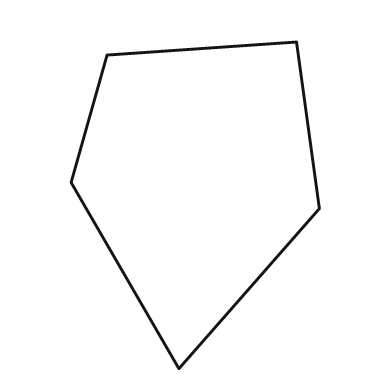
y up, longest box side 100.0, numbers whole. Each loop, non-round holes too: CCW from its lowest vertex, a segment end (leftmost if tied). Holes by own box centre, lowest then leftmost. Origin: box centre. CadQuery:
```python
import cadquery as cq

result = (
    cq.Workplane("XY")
    .moveTo(-5.0, -50.0)
    .lineTo(38.0, -1.0)
    .lineTo(31.0, 50.0)
    .lineTo(-27.0, 46.0)
    .lineTo(-38.0, 7.0)
    .close()
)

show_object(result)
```